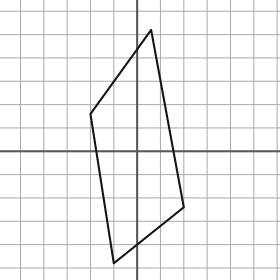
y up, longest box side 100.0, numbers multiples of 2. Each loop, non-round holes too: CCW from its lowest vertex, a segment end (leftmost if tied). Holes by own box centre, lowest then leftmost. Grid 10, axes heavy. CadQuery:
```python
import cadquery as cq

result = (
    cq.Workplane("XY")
    .moveTo(-10.0, -48.0)
    .lineTo(20.0, -24.0)
    .lineTo(6.0, 52.0)
    .lineTo(-20.0, 16.0)
    .close()
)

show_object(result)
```